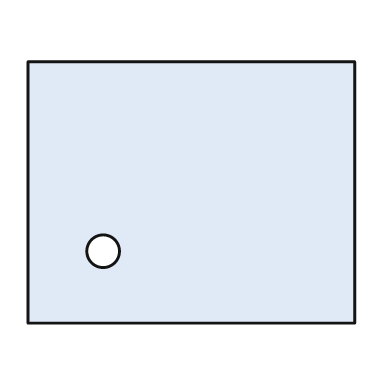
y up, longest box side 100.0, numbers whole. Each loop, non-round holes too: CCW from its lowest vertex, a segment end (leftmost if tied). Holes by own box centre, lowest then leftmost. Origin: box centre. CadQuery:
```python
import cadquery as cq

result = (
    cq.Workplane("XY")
    .moveTo(-50.0, -40.0)
    .lineTo(50.0, -40.0)
    .lineTo(50.0, 40.0)
    .lineTo(-50.0, 40.0)
    .close()
    .moveTo(-27.0, -18.0)
    .circle(5.0)
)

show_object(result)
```